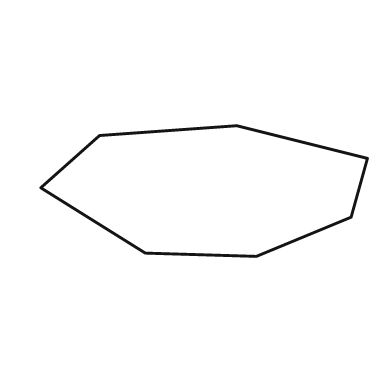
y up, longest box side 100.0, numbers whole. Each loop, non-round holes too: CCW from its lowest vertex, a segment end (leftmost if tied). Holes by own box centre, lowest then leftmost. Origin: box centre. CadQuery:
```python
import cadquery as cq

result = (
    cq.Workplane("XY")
    .moveTo(16.0, -20.0)
    .lineTo(45.0, -8.0)
    .lineTo(50.0, 10.0)
    .lineTo(10.0, 20.0)
    .lineTo(-32.0, 17.0)
    .lineTo(-50.0, 1.0)
    .lineTo(-18.0, -19.0)
    .close()
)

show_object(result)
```